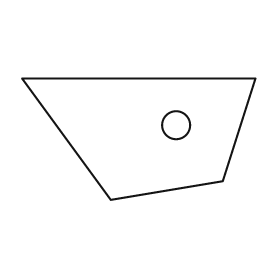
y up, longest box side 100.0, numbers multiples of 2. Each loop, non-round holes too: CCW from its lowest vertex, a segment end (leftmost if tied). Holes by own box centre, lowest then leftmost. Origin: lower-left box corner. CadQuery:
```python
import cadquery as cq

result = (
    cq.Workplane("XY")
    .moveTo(38.0, 0.0)
    .lineTo(86.0, 8.0)
    .lineTo(100.0, 52.0)
    .lineTo(0.0, 52.0)
    .close()
    .moveTo(66.0, 32.0)
    .circle(6.0)
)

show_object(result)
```